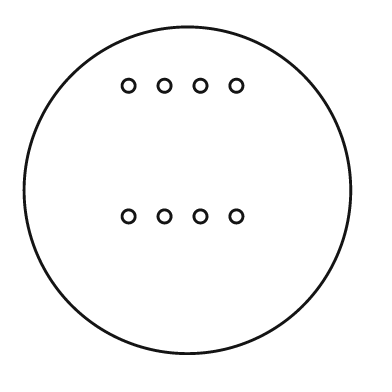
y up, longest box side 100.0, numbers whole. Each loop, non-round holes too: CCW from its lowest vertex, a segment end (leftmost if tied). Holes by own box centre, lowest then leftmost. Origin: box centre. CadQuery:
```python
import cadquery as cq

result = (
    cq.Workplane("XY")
    .moveTo(0.0, 0.0)
    .circle(50.0)
    .moveTo(-18.0, -8.0)
    .circle(2.0)
    .moveTo(-7.0, -8.0)
    .circle(2.0)
    .moveTo(4.0, -8.0)
    .circle(2.0)
    .moveTo(15.0, -8.0)
    .circle(2.0)
    .moveTo(-18.0, 32.0)
    .circle(2.0)
    .moveTo(-7.0, 32.0)
    .circle(2.0)
    .moveTo(4.0, 32.0)
    .circle(2.0)
    .moveTo(15.0, 32.0)
    .circle(2.0)
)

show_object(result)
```